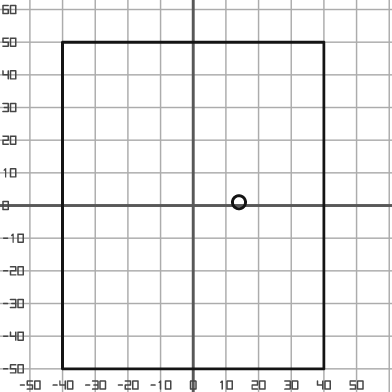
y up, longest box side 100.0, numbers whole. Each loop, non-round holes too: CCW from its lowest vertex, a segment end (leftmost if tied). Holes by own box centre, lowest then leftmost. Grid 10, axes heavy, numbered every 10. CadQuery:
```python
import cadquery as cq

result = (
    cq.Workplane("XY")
    .moveTo(-40.0, -50.0)
    .lineTo(40.0, -50.0)
    .lineTo(40.0, 50.0)
    .lineTo(-40.0, 50.0)
    .close()
    .moveTo(14.0, 1.0)
    .circle(2.0)
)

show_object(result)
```